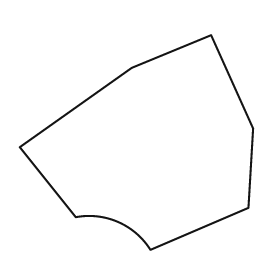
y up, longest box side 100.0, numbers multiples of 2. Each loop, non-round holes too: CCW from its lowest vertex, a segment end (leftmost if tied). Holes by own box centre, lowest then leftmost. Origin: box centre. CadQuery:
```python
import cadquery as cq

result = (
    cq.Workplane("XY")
    .moveTo(6.0, -46.0)
    .lineTo(48.0, -28.0)
    .lineTo(50.0, 6.0)
    .lineTo(32.0, 46.0)
    .lineTo(-2.0, 32.0)
    .lineTo(-50.0, -2.0)
    .lineTo(-26.0, -32.0)
    .threePointArc((-8.0, -34.0), (6.0, -46.0))
    .close()
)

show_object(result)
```